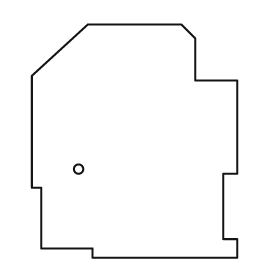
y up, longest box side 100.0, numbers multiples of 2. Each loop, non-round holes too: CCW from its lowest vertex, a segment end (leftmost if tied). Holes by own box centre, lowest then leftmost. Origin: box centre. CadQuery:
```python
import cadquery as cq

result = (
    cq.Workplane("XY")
    .moveTo(-18.0, -50.0)
    .lineTo(44.0, -50.0)
    .lineTo(44.0, -42.0)
    .lineTo(38.0, -42.0)
    .lineTo(38.0, -14.0)
    .lineTo(44.0, -14.0)
    .lineTo(44.0, 26.0)
    .lineTo(26.0, 26.0)
    .lineTo(26.0, 44.0)
    .lineTo(20.0, 50.0)
    .lineTo(-20.0, 50.0)
    .lineTo(-44.0, 28.0)
    .lineTo(-44.0, -20.0)
    .lineTo(-40.0, -20.0)
    .lineTo(-40.0, -46.0)
    .lineTo(-18.0, -46.0)
    .close()
    .moveTo(-24.0, -12.0)
    .circle(2.0)
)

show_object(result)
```